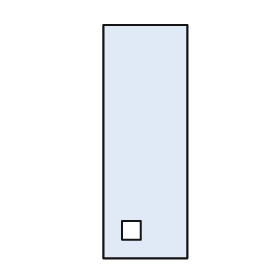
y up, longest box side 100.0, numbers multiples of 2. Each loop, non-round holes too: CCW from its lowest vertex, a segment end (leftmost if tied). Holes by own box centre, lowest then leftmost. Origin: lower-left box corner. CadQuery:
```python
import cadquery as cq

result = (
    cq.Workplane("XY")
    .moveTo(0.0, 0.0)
    .lineTo(36.0, 0.0)
    .lineTo(36.0, 100.0)
    .lineTo(0.0, 100.0)
    .close()
    .moveTo(8.0, 8.0)
    .lineTo(16.0, 8.0)
    .lineTo(16.0, 16.0)
    .lineTo(8.0, 16.0)
    .close()
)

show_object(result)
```